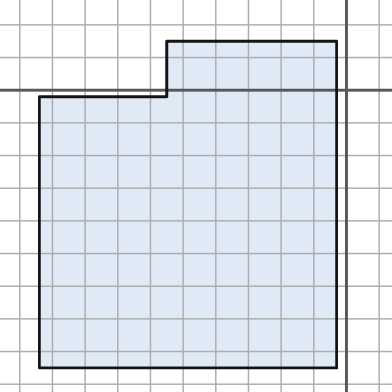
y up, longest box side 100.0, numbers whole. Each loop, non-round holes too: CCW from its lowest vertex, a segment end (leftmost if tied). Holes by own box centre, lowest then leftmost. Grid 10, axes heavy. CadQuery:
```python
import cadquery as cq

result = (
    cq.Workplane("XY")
    .moveTo(-94.0, -85.0)
    .lineTo(-3.0, -85.0)
    .lineTo(-3.0, 15.0)
    .lineTo(-55.0, 15.0)
    .lineTo(-55.0, -2.0)
    .lineTo(-94.0, -2.0)
    .close()
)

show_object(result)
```